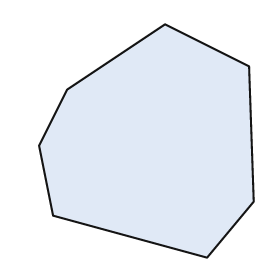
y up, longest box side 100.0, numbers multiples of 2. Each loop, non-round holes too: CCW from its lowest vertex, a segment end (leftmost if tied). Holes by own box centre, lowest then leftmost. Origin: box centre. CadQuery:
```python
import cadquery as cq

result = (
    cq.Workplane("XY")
    .moveTo(26.0, -50.0)
    .lineTo(46.0, -26.0)
    .lineTo(44.0, 32.0)
    .lineTo(8.0, 50.0)
    .lineTo(-34.0, 22.0)
    .lineTo(-46.0, -2.0)
    .lineTo(-40.0, -32.0)
    .close()
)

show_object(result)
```